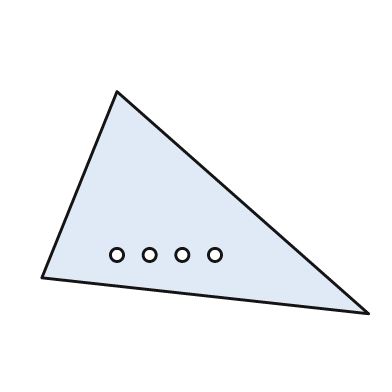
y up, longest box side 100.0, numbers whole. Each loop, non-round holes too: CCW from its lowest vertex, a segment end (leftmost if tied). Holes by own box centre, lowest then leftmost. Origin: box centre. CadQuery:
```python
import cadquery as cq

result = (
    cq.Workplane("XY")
    .moveTo(50.0, -34.0)
    .lineTo(-27.0, 34.0)
    .lineTo(-50.0, -23.0)
    .close()
    .moveTo(-27.0, -16.0)
    .circle(2.0)
    .moveTo(-17.0, -16.0)
    .circle(2.0)
    .moveTo(-7.0, -16.0)
    .circle(2.0)
    .moveTo(3.0, -16.0)
    .circle(2.0)
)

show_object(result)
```